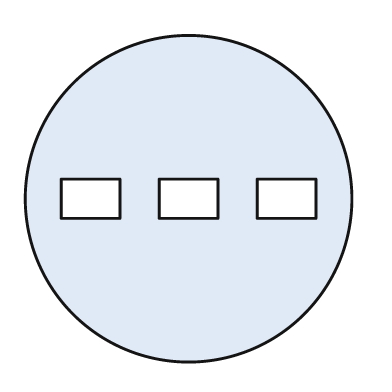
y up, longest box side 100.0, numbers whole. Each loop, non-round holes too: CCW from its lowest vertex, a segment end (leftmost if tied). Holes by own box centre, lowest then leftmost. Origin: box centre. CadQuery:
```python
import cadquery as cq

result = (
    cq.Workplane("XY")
    .moveTo(0.0, 0.0)
    .circle(50.0)
    .moveTo(-39.0, -6.0)
    .lineTo(-21.0, -6.0)
    .lineTo(-21.0, 6.0)
    .lineTo(-39.0, 6.0)
    .close()
    .moveTo(-9.0, -6.0)
    .lineTo(9.0, -6.0)
    .lineTo(9.0, 6.0)
    .lineTo(-9.0, 6.0)
    .close()
    .moveTo(21.0, -6.0)
    .lineTo(39.0, -6.0)
    .lineTo(39.0, 6.0)
    .lineTo(21.0, 6.0)
    .close()
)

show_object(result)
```